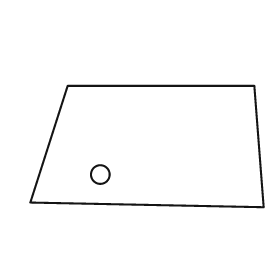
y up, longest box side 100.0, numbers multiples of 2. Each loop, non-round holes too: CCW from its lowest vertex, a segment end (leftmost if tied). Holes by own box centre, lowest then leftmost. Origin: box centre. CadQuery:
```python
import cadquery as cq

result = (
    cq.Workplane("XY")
    .moveTo(50.0, -26.0)
    .lineTo(46.0, 26.0)
    .lineTo(-34.0, 26.0)
    .lineTo(-50.0, -24.0)
    .close()
    .moveTo(-20.0, -12.0)
    .circle(4.0)
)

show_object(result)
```